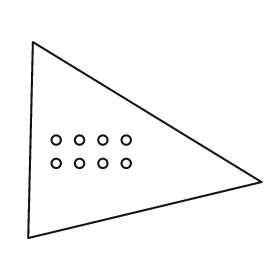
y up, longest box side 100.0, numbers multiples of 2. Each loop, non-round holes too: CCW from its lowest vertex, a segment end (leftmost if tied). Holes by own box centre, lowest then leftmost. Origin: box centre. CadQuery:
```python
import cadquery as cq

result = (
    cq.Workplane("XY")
    .moveTo(-50.0, -42.0)
    .lineTo(50.0, -18.0)
    .lineTo(-48.0, 42.0)
    .close()
    .moveTo(-38.0, -10.0)
    .circle(2.0)
    .moveTo(-28.0, -10.0)
    .circle(2.0)
    .moveTo(-18.0, -10.0)
    .circle(2.0)
    .moveTo(-8.0, -10.0)
    .circle(2.0)
    .moveTo(-38.0, 0.0)
    .circle(2.0)
    .moveTo(-28.0, 0.0)
    .circle(2.0)
    .moveTo(-18.0, 0.0)
    .circle(2.0)
    .moveTo(-8.0, 0.0)
    .circle(2.0)
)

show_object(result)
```